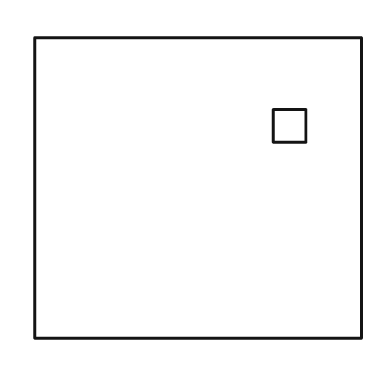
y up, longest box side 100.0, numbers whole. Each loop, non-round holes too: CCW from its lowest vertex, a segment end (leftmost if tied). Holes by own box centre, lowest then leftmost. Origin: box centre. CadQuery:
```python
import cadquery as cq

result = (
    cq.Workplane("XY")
    .moveTo(-50.0, -46.0)
    .lineTo(50.0, -46.0)
    .lineTo(50.0, 46.0)
    .lineTo(-50.0, 46.0)
    .close()
    .moveTo(23.0, 14.0)
    .lineTo(33.0, 14.0)
    .lineTo(33.0, 24.0)
    .lineTo(23.0, 24.0)
    .close()
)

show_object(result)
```